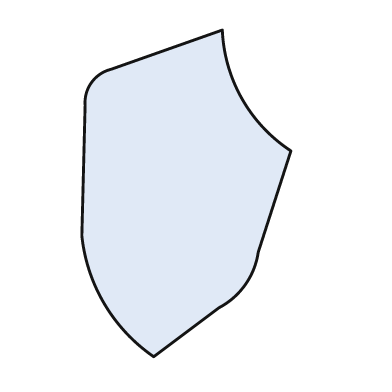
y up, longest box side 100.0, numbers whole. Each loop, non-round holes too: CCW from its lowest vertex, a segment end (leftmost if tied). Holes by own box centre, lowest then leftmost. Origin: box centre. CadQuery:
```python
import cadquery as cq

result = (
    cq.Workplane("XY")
    .moveTo(-10.0, -50.0)
    .lineTo(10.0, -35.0)
    .threePointArc((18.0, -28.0), (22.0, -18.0))
    .lineTo(32.0, 13.0)
    .threePointArc((17.0, 29.0), (11.0, 50.0))
    .lineTo(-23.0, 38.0)
    .threePointArc((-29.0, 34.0), (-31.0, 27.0))
    .lineTo(-32.0, -13.0)
    .threePointArc((-25.0, -34.0), (-10.0, -50.0))
    .close()
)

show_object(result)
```